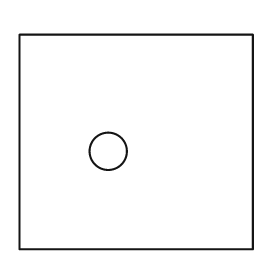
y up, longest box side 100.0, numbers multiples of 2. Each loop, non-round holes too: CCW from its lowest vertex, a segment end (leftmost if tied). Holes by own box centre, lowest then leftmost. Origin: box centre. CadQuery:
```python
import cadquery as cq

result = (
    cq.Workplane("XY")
    .moveTo(-50.0, -46.0)
    .lineTo(50.0, -46.0)
    .lineTo(50.0, 46.0)
    .lineTo(-50.0, 46.0)
    .close()
    .moveTo(-12.0, -4.0)
    .circle(8.0)
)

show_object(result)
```